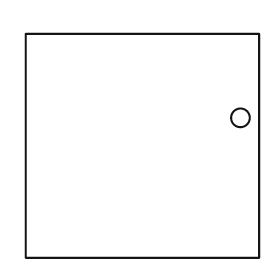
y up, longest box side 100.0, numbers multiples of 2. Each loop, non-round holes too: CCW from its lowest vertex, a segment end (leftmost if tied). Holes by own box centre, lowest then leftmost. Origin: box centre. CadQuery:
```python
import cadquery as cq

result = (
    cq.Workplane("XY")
    .moveTo(-50.0, -48.0)
    .lineTo(50.0, -48.0)
    .lineTo(50.0, 48.0)
    .lineTo(-50.0, 48.0)
    .close()
    .moveTo(42.0, 12.0)
    .circle(4.0)
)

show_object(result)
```